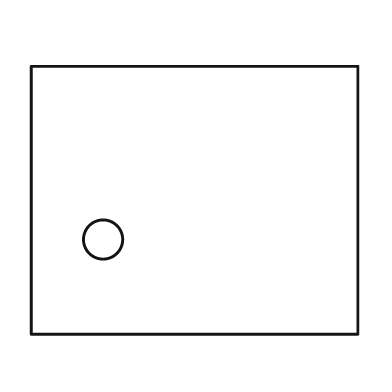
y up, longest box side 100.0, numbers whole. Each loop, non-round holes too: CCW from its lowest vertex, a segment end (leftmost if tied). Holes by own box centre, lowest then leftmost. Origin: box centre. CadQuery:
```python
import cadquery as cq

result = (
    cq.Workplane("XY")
    .moveTo(-50.0, -41.0)
    .lineTo(50.0, -41.0)
    .lineTo(50.0, 41.0)
    .lineTo(-50.0, 41.0)
    .close()
    .moveTo(-28.0, -12.0)
    .circle(6.0)
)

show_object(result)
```